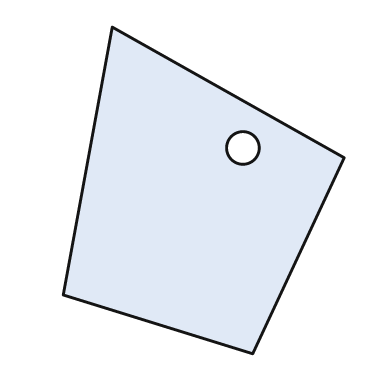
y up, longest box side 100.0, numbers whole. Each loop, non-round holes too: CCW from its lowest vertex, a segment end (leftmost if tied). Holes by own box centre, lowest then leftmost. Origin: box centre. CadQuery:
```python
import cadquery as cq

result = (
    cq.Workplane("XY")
    .moveTo(15.0, -50.0)
    .lineTo(43.0, 10.0)
    .lineTo(-28.0, 50.0)
    .lineTo(-43.0, -32.0)
    .close()
    .moveTo(12.0, 13.0)
    .circle(5.0)
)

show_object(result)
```